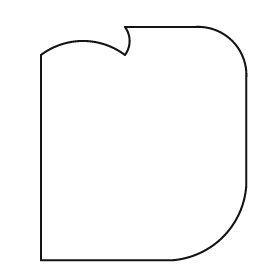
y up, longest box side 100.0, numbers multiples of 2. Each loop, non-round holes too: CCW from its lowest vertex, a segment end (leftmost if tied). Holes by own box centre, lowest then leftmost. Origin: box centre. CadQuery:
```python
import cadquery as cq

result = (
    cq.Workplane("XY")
    .moveTo(-44.0, -50.0)
    .lineTo(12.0, -50.0)
    .threePointArc((34.0, -40.0), (44.0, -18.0))
    .lineTo(44.0, 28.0)
    .threePointArc((38.0, 44.0), (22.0, 50.0))
    .lineTo(-8.0, 50.0)
    .threePointArc((-6.0, 44.0), (-8.0, 38.0))
    .threePointArc((-26.0, 44.0), (-44.0, 38.0))
    .close()
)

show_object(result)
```